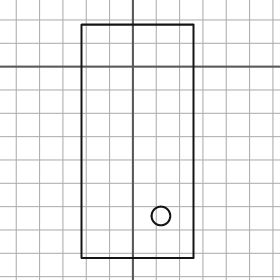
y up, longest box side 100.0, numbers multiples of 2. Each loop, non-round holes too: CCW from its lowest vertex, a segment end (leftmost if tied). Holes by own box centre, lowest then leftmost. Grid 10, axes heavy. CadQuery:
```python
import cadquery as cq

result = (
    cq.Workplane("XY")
    .moveTo(-22.0, -82.0)
    .lineTo(26.0, -82.0)
    .lineTo(26.0, 18.0)
    .lineTo(-22.0, 18.0)
    .close()
    .moveTo(12.0, -64.0)
    .circle(4.0)
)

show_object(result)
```